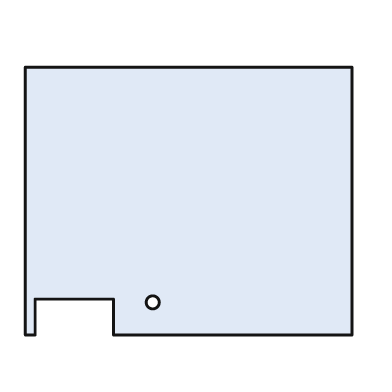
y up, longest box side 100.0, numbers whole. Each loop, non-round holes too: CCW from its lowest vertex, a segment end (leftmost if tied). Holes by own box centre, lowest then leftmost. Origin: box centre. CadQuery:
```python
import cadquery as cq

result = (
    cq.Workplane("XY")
    .moveTo(-50.0, -41.0)
    .lineTo(-47.0, -41.0)
    .lineTo(-47.0, -30.0)
    .lineTo(-23.0, -30.0)
    .lineTo(-23.0, -41.0)
    .lineTo(50.0, -41.0)
    .lineTo(50.0, 41.0)
    .lineTo(-50.0, 41.0)
    .close()
    .moveTo(-11.0, -31.0)
    .circle(2.0)
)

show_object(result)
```